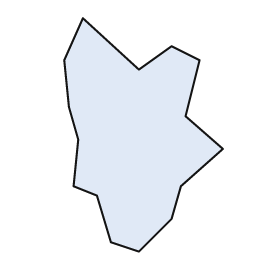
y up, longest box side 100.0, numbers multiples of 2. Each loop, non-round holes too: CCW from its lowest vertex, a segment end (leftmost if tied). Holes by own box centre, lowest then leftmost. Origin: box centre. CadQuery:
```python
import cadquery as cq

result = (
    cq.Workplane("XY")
    .moveTo(-2.0, -50.0)
    .lineTo(12.0, -36.0)
    .lineTo(16.0, -22.0)
    .lineTo(34.0, -6.0)
    .lineTo(18.0, 8.0)
    .lineTo(24.0, 32.0)
    .lineTo(12.0, 38.0)
    .lineTo(-2.0, 28.0)
    .lineTo(-26.0, 50.0)
    .lineTo(-34.0, 32.0)
    .lineTo(-32.0, 12.0)
    .lineTo(-28.0, -2.0)
    .lineTo(-30.0, -22.0)
    .lineTo(-20.0, -26.0)
    .lineTo(-14.0, -46.0)
    .close()
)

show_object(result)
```